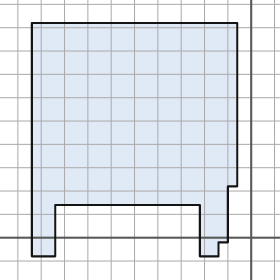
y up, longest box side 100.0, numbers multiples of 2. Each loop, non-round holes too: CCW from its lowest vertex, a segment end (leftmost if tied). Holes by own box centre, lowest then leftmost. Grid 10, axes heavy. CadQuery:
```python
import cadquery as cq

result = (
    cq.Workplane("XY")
    .moveTo(-94.0, -8.0)
    .lineTo(-84.0, -8.0)
    .lineTo(-84.0, 14.0)
    .lineTo(-22.0, 14.0)
    .lineTo(-22.0, -8.0)
    .lineTo(-14.0, -8.0)
    .lineTo(-14.0, -2.0)
    .lineTo(-10.0, -2.0)
    .lineTo(-10.0, 22.0)
    .lineTo(-6.0, 22.0)
    .lineTo(-6.0, 92.0)
    .lineTo(-94.0, 92.0)
    .close()
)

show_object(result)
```